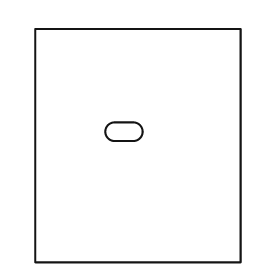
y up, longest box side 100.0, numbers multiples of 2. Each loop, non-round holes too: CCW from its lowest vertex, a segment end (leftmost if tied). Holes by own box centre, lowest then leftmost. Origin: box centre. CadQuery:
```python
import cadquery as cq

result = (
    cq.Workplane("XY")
    .moveTo(-44.0, -50.0)
    .lineTo(44.0, -50.0)
    .lineTo(44.0, 50.0)
    .lineTo(-44.0, 50.0)
    .close()
    .moveTo(-10.0, 2.0)
    .lineTo(-2.0, 2.0)
    .threePointArc((2.0, 6.0), (-2.0, 10.0))
    .lineTo(-10.0, 10.0)
    .threePointArc((-14.0, 6.0), (-10.0, 2.0))
    .close()
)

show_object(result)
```